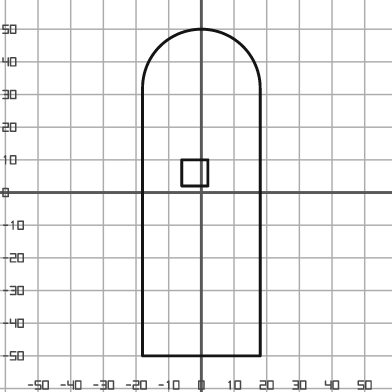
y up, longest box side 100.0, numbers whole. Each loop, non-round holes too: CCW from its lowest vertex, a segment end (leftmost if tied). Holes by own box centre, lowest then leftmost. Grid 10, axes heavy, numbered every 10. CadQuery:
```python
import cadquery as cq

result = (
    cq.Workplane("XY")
    .moveTo(-18.0, -50.0)
    .lineTo(18.0, -50.0)
    .lineTo(18.0, 32.0)
    .threePointArc((0.0, 50.0), (-18.0, 32.0))
    .close()
    .moveTo(-6.0, 2.0)
    .lineTo(2.0, 2.0)
    .lineTo(2.0, 10.0)
    .lineTo(-6.0, 10.0)
    .close()
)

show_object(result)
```